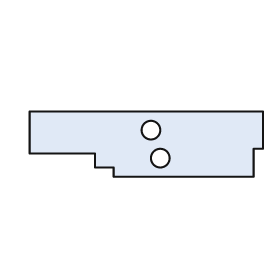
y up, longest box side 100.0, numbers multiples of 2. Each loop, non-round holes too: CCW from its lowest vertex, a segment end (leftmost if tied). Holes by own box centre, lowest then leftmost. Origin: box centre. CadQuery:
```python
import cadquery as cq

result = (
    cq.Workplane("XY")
    .moveTo(-14.0, -14.0)
    .lineTo(46.0, -14.0)
    .lineTo(46.0, -2.0)
    .lineTo(50.0, -2.0)
    .lineTo(50.0, 14.0)
    .lineTo(-50.0, 14.0)
    .lineTo(-50.0, -4.0)
    .lineTo(-22.0, -4.0)
    .lineTo(-22.0, -10.0)
    .lineTo(-14.0, -10.0)
    .close()
    .moveTo(6.0, -6.0)
    .circle(4.0)
    .moveTo(2.0, 6.0)
    .circle(4.0)
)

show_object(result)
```